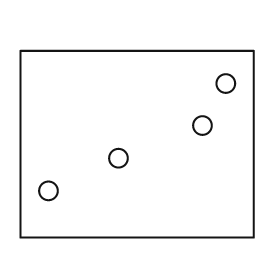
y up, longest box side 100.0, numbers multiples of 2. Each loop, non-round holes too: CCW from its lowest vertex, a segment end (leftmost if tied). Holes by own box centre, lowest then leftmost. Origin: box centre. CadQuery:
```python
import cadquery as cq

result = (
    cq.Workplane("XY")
    .moveTo(-50.0, -40.0)
    .lineTo(50.0, -40.0)
    .lineTo(50.0, 40.0)
    .lineTo(-50.0, 40.0)
    .close()
    .moveTo(-38.0, -20.0)
    .circle(4.0)
    .moveTo(-8.0, -6.0)
    .circle(4.0)
    .moveTo(28.0, 8.0)
    .circle(4.0)
    .moveTo(38.0, 26.0)
    .circle(4.0)
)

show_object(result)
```